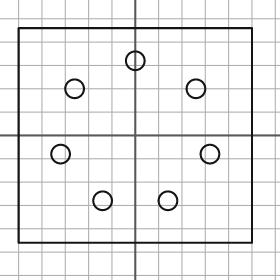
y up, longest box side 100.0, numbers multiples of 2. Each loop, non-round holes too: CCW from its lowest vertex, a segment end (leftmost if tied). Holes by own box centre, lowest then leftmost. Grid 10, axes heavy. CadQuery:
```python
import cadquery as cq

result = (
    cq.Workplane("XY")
    .moveTo(-50.0, -46.0)
    .lineTo(50.0, -46.0)
    .lineTo(50.0, 46.0)
    .lineTo(-50.0, 46.0)
    .close()
    .moveTo(-14.0, -28.0)
    .circle(4.0)
    .moveTo(14.0, -28.0)
    .circle(4.0)
    .moveTo(-32.0, -8.0)
    .circle(4.0)
    .moveTo(32.0, -8.0)
    .circle(4.0)
    .moveTo(-26.0, 20.0)
    .circle(4.0)
    .moveTo(26.0, 20.0)
    .circle(4.0)
    .moveTo(0.0, 32.0)
    .circle(4.0)
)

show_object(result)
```